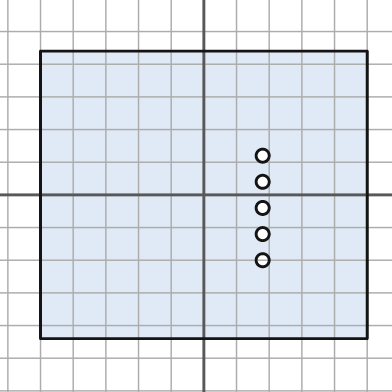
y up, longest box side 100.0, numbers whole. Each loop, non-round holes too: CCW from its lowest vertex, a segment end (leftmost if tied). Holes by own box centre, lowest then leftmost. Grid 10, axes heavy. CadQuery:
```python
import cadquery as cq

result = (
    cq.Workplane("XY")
    .moveTo(-50.0, -44.0)
    .lineTo(50.0, -44.0)
    .lineTo(50.0, 44.0)
    .lineTo(-50.0, 44.0)
    .close()
    .moveTo(18.0, -20.0)
    .circle(2.0)
    .moveTo(18.0, -12.0)
    .circle(2.0)
    .moveTo(18.0, -4.0)
    .circle(2.0)
    .moveTo(18.0, 4.0)
    .circle(2.0)
    .moveTo(18.0, 12.0)
    .circle(2.0)
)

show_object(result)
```